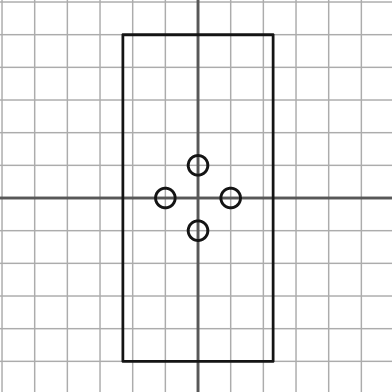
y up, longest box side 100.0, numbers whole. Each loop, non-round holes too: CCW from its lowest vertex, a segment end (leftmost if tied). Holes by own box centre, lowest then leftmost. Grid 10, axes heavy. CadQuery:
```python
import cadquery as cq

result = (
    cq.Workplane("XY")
    .moveTo(-23.0, -50.0)
    .lineTo(23.0, -50.0)
    .lineTo(23.0, 50.0)
    .lineTo(-23.0, 50.0)
    .close()
    .moveTo(0.0, -10.0)
    .circle(3.0)
    .moveTo(-10.0, 0.0)
    .circle(3.0)
    .moveTo(10.0, 0.0)
    .circle(3.0)
    .moveTo(0.0, 10.0)
    .circle(3.0)
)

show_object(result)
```